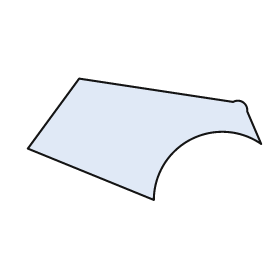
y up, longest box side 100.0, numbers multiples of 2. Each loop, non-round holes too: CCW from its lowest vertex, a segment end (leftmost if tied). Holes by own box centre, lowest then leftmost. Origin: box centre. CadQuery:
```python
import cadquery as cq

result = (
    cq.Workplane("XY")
    .moveTo(4.0, -26.0)
    .threePointArc((20.0, 0.0), (50.0, -2.0))
    .lineTo(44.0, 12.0)
    .threePointArc((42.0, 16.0), (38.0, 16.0))
    .lineTo(-28.0, 26.0)
    .lineTo(-50.0, -4.0)
    .close()
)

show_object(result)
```